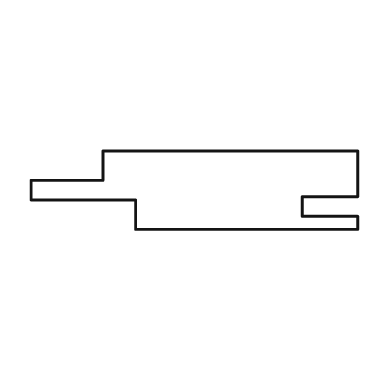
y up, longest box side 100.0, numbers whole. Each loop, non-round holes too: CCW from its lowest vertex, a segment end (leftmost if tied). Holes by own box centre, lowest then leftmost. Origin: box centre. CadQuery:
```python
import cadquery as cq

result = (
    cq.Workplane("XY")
    .moveTo(-18.0, -12.0)
    .lineTo(50.0, -12.0)
    .lineTo(50.0, -8.0)
    .lineTo(33.0, -8.0)
    .lineTo(33.0, -2.0)
    .lineTo(50.0, -2.0)
    .lineTo(50.0, 12.0)
    .lineTo(-28.0, 12.0)
    .lineTo(-28.0, 3.0)
    .lineTo(-50.0, 3.0)
    .lineTo(-50.0, -3.0)
    .lineTo(-18.0, -3.0)
    .close()
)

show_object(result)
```